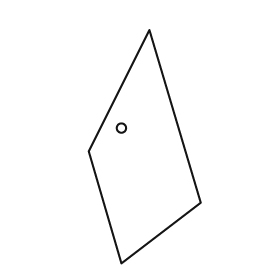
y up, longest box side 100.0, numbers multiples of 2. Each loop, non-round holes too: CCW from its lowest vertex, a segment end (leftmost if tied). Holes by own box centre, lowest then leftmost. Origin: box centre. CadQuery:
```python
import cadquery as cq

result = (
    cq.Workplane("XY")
    .moveTo(-10.0, -50.0)
    .lineTo(24.0, -24.0)
    .lineTo(2.0, 50.0)
    .lineTo(-24.0, -2.0)
    .close()
    .moveTo(-10.0, 8.0)
    .circle(2.0)
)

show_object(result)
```